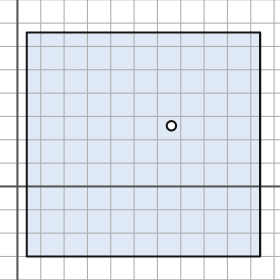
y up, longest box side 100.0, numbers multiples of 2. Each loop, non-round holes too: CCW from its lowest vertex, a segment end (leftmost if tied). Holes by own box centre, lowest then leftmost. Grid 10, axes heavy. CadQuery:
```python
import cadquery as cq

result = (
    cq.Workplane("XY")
    .moveTo(4.0, -30.0)
    .lineTo(104.0, -30.0)
    .lineTo(104.0, 66.0)
    .lineTo(4.0, 66.0)
    .close()
    .moveTo(66.0, 26.0)
    .circle(2.0)
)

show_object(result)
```